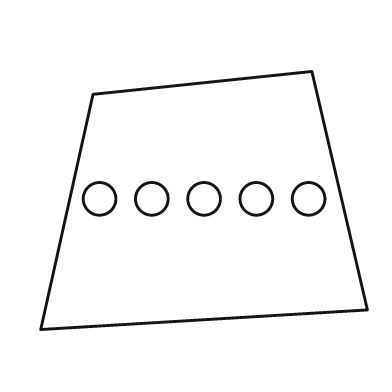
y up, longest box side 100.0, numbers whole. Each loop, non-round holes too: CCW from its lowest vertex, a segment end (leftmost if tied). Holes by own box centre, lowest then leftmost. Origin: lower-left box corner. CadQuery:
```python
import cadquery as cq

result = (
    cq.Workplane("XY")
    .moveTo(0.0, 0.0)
    .lineTo(100.0, 6.0)
    .lineTo(83.0, 79.0)
    .lineTo(16.0, 72.0)
    .close()
    .moveTo(18.0, 40.0)
    .circle(5.0)
    .moveTo(34.0, 40.0)
    .circle(5.0)
    .moveTo(50.0, 40.0)
    .circle(5.0)
    .moveTo(66.0, 40.0)
    .circle(5.0)
    .moveTo(82.0, 40.0)
    .circle(5.0)
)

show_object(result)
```